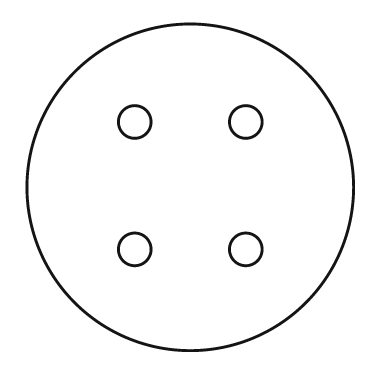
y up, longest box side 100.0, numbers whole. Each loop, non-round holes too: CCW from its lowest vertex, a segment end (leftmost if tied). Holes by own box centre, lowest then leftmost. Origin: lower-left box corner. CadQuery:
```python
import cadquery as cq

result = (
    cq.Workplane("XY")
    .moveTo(50.0, 50.0)
    .circle(50.0)
    .moveTo(33.0, 31.0)
    .circle(5.0)
    .moveTo(67.0, 31.0)
    .circle(5.0)
    .moveTo(33.0, 70.0)
    .circle(5.0)
    .moveTo(67.0, 70.0)
    .circle(5.0)
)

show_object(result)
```